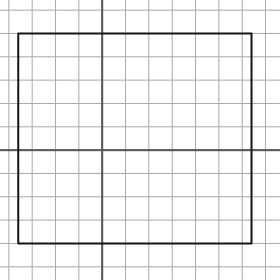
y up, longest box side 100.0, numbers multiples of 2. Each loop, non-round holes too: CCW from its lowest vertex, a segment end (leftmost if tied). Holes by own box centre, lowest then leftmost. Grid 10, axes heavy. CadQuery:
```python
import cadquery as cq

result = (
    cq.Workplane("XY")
    .moveTo(-36.0, -40.0)
    .lineTo(64.0, -40.0)
    .lineTo(64.0, 50.0)
    .lineTo(-36.0, 50.0)
    .close()
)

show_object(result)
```